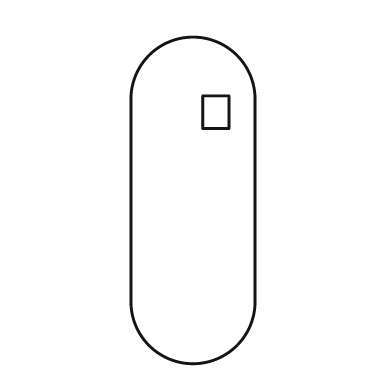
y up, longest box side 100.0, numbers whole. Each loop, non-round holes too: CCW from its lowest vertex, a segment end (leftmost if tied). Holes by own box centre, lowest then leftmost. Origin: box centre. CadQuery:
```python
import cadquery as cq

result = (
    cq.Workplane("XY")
    .moveTo(-19.0, -31.0)
    .threePointArc((0.0, -50.0), (19.0, -31.0))
    .lineTo(19.0, 31.0)
    .threePointArc((0.0, 50.0), (-19.0, 31.0))
    .close()
    .moveTo(3.0, 22.0)
    .lineTo(11.0, 22.0)
    .lineTo(11.0, 32.0)
    .lineTo(3.0, 32.0)
    .close()
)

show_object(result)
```